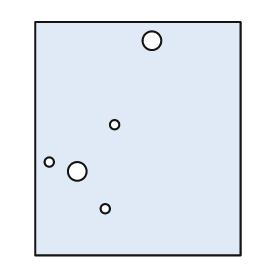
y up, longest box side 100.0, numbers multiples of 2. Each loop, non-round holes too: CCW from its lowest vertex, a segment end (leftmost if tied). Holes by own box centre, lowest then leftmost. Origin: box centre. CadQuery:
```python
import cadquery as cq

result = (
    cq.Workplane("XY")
    .moveTo(-44.0, -50.0)
    .lineTo(44.0, -50.0)
    .lineTo(44.0, 50.0)
    .lineTo(-44.0, 50.0)
    .close()
    .moveTo(-14.0, -30.0)
    .circle(2.0)
    .moveTo(-26.0, -14.0)
    .circle(4.0)
    .moveTo(-38.0, -10.0)
    .circle(2.0)
    .moveTo(-10.0, 6.0)
    .circle(2.0)
    .moveTo(6.0, 42.0)
    .circle(4.0)
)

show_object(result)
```